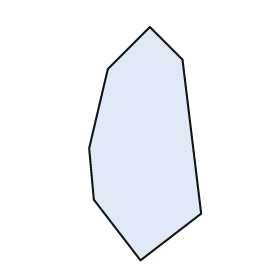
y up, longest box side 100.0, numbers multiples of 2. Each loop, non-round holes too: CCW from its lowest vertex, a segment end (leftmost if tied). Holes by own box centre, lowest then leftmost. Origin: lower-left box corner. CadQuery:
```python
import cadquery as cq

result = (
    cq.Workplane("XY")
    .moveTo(22.0, 0.0)
    .lineTo(48.0, 20.0)
    .lineTo(40.0, 86.0)
    .lineTo(26.0, 100.0)
    .lineTo(8.0, 82.0)
    .lineTo(0.0, 48.0)
    .lineTo(2.0, 26.0)
    .close()
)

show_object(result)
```